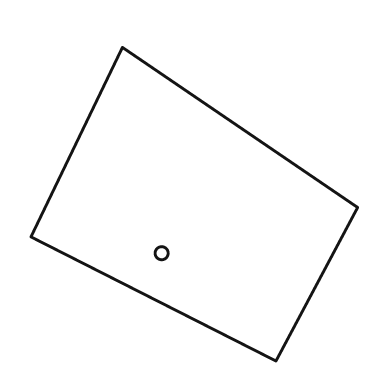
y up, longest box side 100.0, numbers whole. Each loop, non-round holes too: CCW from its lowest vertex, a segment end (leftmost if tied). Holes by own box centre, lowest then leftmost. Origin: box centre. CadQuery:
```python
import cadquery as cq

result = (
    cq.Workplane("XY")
    .moveTo(25.0, -48.0)
    .lineTo(50.0, -1.0)
    .lineTo(-22.0, 48.0)
    .lineTo(-50.0, -10.0)
    .close()
    .moveTo(-10.0, -15.0)
    .circle(2.0)
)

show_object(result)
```